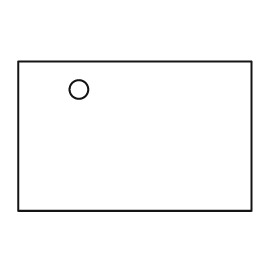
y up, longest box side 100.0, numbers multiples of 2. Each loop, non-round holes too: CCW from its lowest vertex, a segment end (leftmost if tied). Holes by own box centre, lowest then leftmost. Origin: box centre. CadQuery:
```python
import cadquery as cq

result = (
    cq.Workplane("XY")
    .moveTo(-50.0, -32.0)
    .lineTo(50.0, -32.0)
    .lineTo(50.0, 32.0)
    .lineTo(-50.0, 32.0)
    .close()
    .moveTo(-24.0, 20.0)
    .circle(4.0)
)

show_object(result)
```